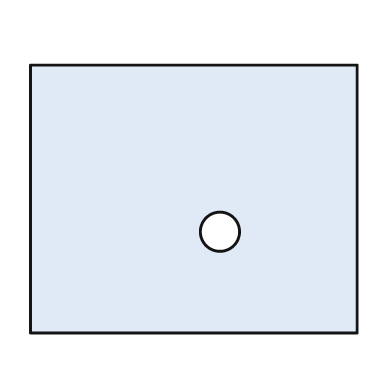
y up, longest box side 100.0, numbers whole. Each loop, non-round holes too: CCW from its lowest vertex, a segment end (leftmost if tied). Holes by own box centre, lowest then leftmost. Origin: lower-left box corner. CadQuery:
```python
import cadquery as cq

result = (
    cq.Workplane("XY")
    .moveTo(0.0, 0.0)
    .lineTo(100.0, 0.0)
    .lineTo(100.0, 82.0)
    .lineTo(0.0, 82.0)
    .close()
    .moveTo(58.0, 31.0)
    .circle(6.0)
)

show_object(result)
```